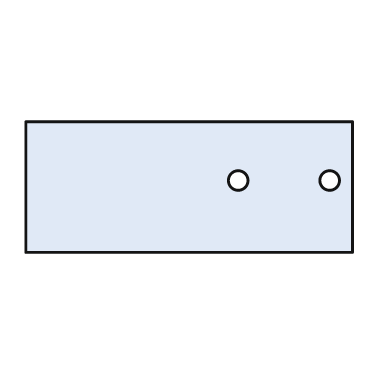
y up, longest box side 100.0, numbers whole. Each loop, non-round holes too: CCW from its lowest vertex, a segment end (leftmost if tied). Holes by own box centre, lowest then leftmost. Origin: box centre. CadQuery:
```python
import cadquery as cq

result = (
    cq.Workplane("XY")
    .moveTo(-50.0, -20.0)
    .lineTo(50.0, -20.0)
    .lineTo(50.0, 20.0)
    .lineTo(-50.0, 20.0)
    .close()
    .moveTo(15.0, 2.0)
    .circle(3.0)
    .moveTo(43.0, 2.0)
    .circle(3.0)
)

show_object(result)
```